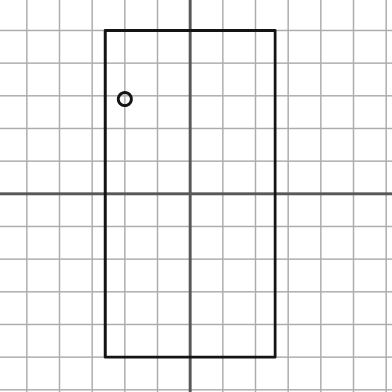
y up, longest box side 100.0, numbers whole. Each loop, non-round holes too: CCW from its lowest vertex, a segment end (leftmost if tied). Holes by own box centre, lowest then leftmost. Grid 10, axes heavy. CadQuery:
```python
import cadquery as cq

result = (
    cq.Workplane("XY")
    .moveTo(-26.0, -50.0)
    .lineTo(26.0, -50.0)
    .lineTo(26.0, 50.0)
    .lineTo(-26.0, 50.0)
    .close()
    .moveTo(-20.0, 29.0)
    .circle(2.0)
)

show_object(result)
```